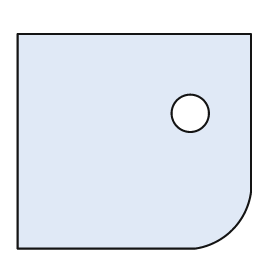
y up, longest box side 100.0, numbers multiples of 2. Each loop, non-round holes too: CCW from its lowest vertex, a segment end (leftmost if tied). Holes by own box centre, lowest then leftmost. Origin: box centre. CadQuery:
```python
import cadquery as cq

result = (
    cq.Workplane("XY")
    .moveTo(-50.0, -46.0)
    .lineTo(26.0, -46.0)
    .threePointArc((42.0, -38.0), (50.0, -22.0))
    .lineTo(50.0, 46.0)
    .lineTo(-50.0, 46.0)
    .close()
    .moveTo(24.0, 12.0)
    .circle(8.0)
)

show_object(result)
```